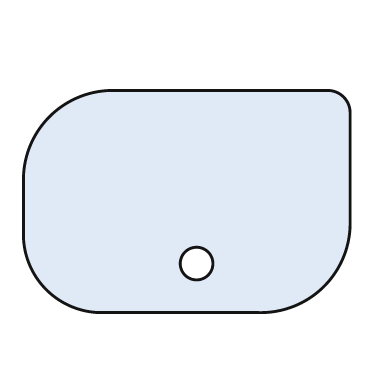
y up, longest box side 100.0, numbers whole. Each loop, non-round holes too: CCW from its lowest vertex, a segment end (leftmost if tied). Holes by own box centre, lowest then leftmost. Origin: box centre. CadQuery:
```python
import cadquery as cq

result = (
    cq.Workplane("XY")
    .moveTo(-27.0, -34.0)
    .lineTo(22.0, -34.0)
    .threePointArc((42.0, -26.0), (50.0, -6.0))
    .lineTo(50.0, 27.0)
    .threePointArc((48.0, 32.0), (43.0, 34.0))
    .lineTo(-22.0, 34.0)
    .threePointArc((-42.0, 26.0), (-50.0, 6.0))
    .lineTo(-50.0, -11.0)
    .threePointArc((-43.0, -27.0), (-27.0, -34.0))
    .close()
    .moveTo(3.0, -19.0)
    .circle(5.0)
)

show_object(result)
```